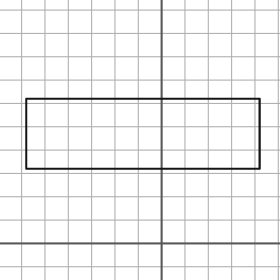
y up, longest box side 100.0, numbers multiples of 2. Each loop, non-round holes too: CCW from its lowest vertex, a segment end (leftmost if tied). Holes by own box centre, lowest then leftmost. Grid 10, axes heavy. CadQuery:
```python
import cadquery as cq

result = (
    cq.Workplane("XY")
    .moveTo(-58.0, 32.0)
    .lineTo(42.0, 32.0)
    .lineTo(42.0, 62.0)
    .lineTo(-58.0, 62.0)
    .close()
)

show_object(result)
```